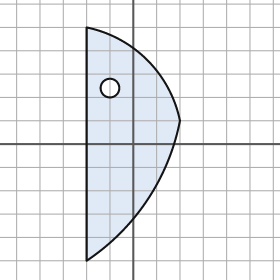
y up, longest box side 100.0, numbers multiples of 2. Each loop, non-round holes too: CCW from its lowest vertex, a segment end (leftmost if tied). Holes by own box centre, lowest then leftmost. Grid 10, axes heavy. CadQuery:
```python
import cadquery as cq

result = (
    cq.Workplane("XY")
    .moveTo(-20.0, -50.0)
    .threePointArc((6.0, -24.0), (20.0, 10.0))
    .threePointArc((6.0, 36.0), (-20.0, 50.0))
    .close()
    .moveTo(-10.0, 24.0)
    .circle(4.0)
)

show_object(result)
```